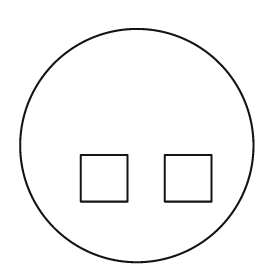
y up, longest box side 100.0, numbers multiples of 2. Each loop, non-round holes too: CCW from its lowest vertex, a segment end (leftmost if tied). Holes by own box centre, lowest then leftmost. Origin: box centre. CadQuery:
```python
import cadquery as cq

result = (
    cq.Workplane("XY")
    .moveTo(0.0, 0.0)
    .circle(50.0)
    .moveTo(-24.0, -24.0)
    .lineTo(-4.0, -24.0)
    .lineTo(-4.0, -4.0)
    .lineTo(-24.0, -4.0)
    .close()
    .moveTo(12.0, -24.0)
    .lineTo(32.0, -24.0)
    .lineTo(32.0, -4.0)
    .lineTo(12.0, -4.0)
    .close()
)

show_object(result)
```